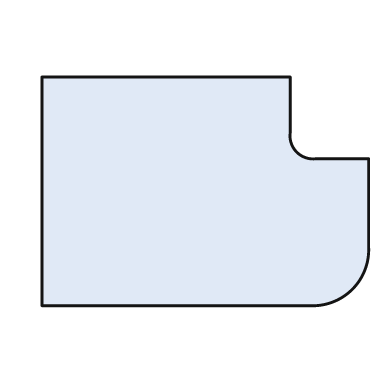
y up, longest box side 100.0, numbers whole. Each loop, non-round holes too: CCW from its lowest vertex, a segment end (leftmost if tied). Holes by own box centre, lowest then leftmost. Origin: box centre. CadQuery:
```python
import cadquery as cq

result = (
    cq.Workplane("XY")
    .moveTo(-50.0, -35.0)
    .lineTo(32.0, -35.0)
    .threePointArc((45.0, -30.0), (50.0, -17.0))
    .lineTo(50.0, 10.0)
    .lineTo(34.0, 10.0)
    .threePointArc((28.0, 12.0), (26.0, 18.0))
    .lineTo(26.0, 35.0)
    .lineTo(-50.0, 35.0)
    .close()
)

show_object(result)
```